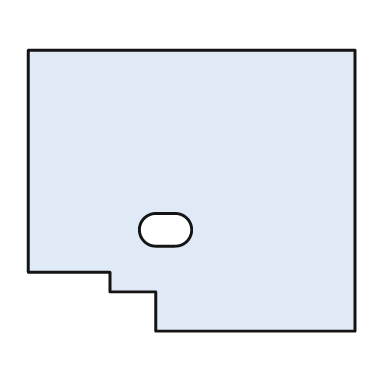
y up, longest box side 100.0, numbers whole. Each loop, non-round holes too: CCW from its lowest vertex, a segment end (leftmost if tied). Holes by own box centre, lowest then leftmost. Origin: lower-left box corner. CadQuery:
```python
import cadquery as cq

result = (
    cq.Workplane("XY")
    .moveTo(39.0, 0.0)
    .lineTo(100.0, 0.0)
    .lineTo(100.0, 86.0)
    .lineTo(0.0, 86.0)
    .lineTo(0.0, 18.0)
    .lineTo(25.0, 18.0)
    .lineTo(25.0, 12.0)
    .lineTo(39.0, 12.0)
    .close()
    .moveTo(39.0, 26.0)
    .lineTo(45.0, 26.0)
    .threePointArc((50.0, 31.0), (45.0, 36.0))
    .lineTo(39.0, 36.0)
    .threePointArc((34.0, 31.0), (39.0, 26.0))
    .close()
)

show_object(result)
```